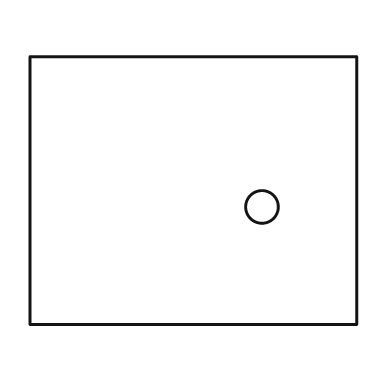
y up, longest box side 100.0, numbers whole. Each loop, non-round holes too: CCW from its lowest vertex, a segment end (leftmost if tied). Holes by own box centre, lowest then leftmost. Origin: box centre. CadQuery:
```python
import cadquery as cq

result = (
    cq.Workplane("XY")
    .moveTo(-50.0, -41.0)
    .lineTo(50.0, -41.0)
    .lineTo(50.0, 41.0)
    .lineTo(-50.0, 41.0)
    .close()
    .moveTo(21.0, -5.0)
    .circle(5.0)
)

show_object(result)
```